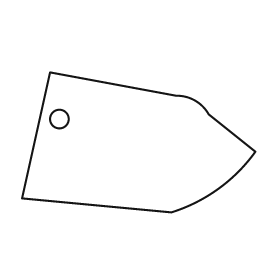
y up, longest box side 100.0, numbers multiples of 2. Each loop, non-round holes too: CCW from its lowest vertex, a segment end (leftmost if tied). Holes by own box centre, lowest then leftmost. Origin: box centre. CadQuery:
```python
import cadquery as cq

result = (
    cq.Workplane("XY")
    .moveTo(14.0, -30.0)
    .threePointArc((34.0, -20.0), (50.0, -4.0))
    .lineTo(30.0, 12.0)
    .threePointArc((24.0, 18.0), (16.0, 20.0))
    .lineTo(-38.0, 30.0)
    .lineTo(-50.0, -24.0)
    .close()
    .moveTo(-34.0, 10.0)
    .circle(4.0)
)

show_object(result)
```